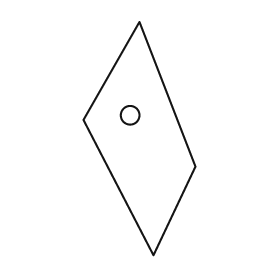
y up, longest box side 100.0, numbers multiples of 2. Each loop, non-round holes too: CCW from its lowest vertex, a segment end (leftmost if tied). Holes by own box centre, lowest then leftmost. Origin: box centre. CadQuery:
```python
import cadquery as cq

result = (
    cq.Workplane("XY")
    .moveTo(6.0, -50.0)
    .lineTo(24.0, -12.0)
    .lineTo(0.0, 50.0)
    .lineTo(-24.0, 8.0)
    .close()
    .moveTo(-4.0, 10.0)
    .circle(4.0)
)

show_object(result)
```